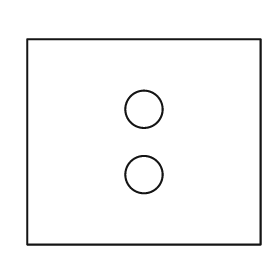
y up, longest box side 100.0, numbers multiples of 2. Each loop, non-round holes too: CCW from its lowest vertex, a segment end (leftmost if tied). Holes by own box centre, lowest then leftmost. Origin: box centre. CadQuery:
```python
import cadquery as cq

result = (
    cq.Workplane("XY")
    .moveTo(-50.0, -44.0)
    .lineTo(50.0, -44.0)
    .lineTo(50.0, 44.0)
    .lineTo(-50.0, 44.0)
    .close()
    .moveTo(0.0, -14.0)
    .circle(8.0)
    .moveTo(0.0, 14.0)
    .circle(8.0)
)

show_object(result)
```